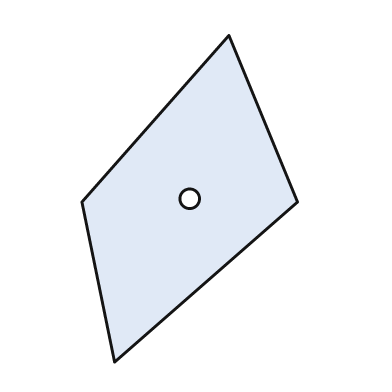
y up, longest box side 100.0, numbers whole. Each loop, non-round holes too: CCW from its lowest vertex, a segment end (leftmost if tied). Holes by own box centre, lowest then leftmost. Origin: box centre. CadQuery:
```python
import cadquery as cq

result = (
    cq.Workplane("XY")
    .moveTo(-23.0, -50.0)
    .lineTo(33.0, -1.0)
    .lineTo(12.0, 50.0)
    .lineTo(-33.0, -1.0)
    .close()
    .moveTo(0.0, 0.0)
    .circle(3.0)
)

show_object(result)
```